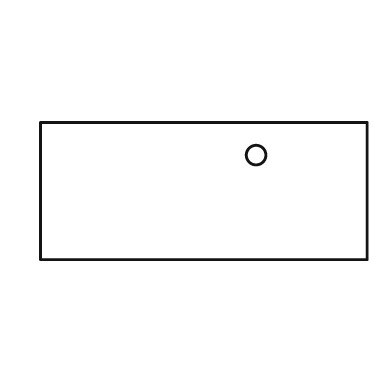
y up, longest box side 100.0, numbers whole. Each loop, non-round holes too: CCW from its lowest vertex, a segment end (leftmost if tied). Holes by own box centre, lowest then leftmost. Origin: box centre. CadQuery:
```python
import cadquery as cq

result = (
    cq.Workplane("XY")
    .moveTo(-50.0, -21.0)
    .lineTo(50.0, -21.0)
    .lineTo(50.0, 21.0)
    .lineTo(-50.0, 21.0)
    .close()
    .moveTo(16.0, 11.0)
    .circle(3.0)
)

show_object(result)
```